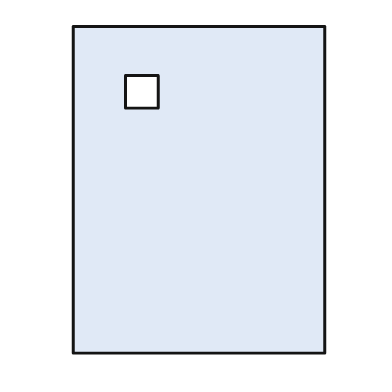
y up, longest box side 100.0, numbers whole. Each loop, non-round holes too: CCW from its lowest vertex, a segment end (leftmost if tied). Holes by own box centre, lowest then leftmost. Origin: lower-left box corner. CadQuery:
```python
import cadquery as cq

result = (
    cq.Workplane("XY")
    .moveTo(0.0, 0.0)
    .lineTo(77.0, 0.0)
    .lineTo(77.0, 100.0)
    .lineTo(0.0, 100.0)
    .close()
    .moveTo(16.0, 75.0)
    .lineTo(26.0, 75.0)
    .lineTo(26.0, 85.0)
    .lineTo(16.0, 85.0)
    .close()
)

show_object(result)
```